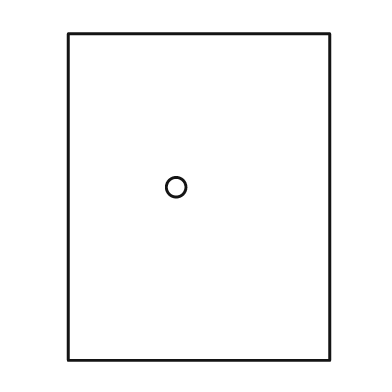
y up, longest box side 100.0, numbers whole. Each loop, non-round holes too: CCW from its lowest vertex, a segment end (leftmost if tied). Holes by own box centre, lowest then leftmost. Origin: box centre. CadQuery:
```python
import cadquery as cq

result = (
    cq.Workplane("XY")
    .moveTo(-40.0, -50.0)
    .lineTo(40.0, -50.0)
    .lineTo(40.0, 50.0)
    .lineTo(-40.0, 50.0)
    .close()
    .moveTo(-7.0, 3.0)
    .circle(3.0)
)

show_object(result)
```